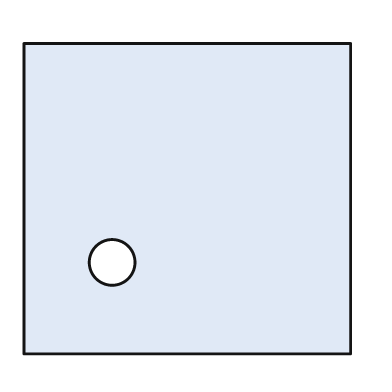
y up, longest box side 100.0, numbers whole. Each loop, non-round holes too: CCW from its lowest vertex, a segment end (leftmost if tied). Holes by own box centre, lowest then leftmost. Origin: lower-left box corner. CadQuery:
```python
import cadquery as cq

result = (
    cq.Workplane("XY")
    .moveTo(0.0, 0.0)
    .lineTo(100.0, 0.0)
    .lineTo(100.0, 95.0)
    .lineTo(0.0, 95.0)
    .close()
    .moveTo(27.0, 28.0)
    .circle(7.0)
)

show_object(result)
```